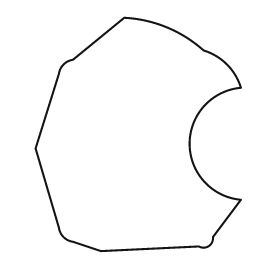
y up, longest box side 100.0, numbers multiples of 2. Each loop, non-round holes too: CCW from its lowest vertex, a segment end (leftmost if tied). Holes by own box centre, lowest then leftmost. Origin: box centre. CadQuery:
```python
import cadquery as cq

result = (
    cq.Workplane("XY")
    .moveTo(-16.0, -50.0)
    .lineTo(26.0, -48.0)
    .threePointArc((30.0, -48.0), (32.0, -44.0))
    .lineTo(44.0, -28.0)
    .threePointArc((22.0, -4.0), (44.0, 20.0))
    .threePointArc((38.0, 30.0), (28.0, 36.0))
    .threePointArc((12.0, 46.0), (-6.0, 50.0))
    .lineTo(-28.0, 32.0)
    .threePointArc((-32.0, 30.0), (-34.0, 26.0))
    .lineTo(-44.0, -6.0)
    .lineTo(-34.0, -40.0)
    .threePointArc((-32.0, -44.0), (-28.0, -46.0))
    .close()
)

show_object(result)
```